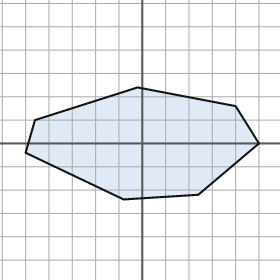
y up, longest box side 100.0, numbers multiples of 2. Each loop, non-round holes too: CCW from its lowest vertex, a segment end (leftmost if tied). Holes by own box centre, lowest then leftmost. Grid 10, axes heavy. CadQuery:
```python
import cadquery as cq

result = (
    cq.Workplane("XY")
    .moveTo(-8.0, -24.0)
    .lineTo(24.0, -22.0)
    .lineTo(50.0, 0.0)
    .lineTo(40.0, 16.0)
    .lineTo(-2.0, 24.0)
    .lineTo(-46.0, 10.0)
    .lineTo(-50.0, -4.0)
    .close()
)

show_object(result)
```